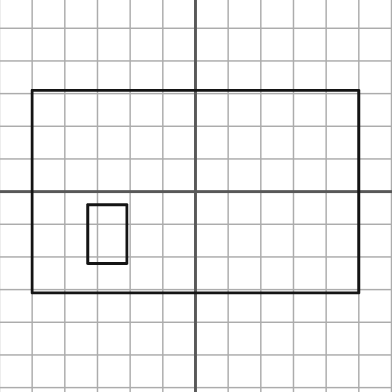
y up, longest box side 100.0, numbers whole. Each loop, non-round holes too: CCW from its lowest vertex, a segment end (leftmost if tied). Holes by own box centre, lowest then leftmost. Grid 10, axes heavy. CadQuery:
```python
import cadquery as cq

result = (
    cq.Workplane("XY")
    .moveTo(-50.0, -31.0)
    .lineTo(50.0, -31.0)
    .lineTo(50.0, 31.0)
    .lineTo(-50.0, 31.0)
    .close()
    .moveTo(-33.0, -22.0)
    .lineTo(-21.0, -22.0)
    .lineTo(-21.0, -4.0)
    .lineTo(-33.0, -4.0)
    .close()
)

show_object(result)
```